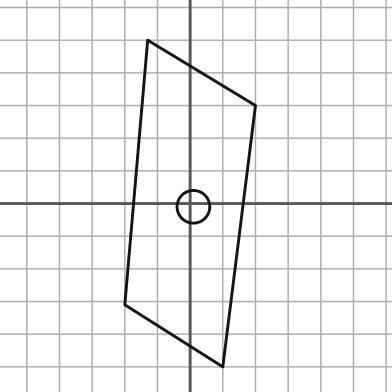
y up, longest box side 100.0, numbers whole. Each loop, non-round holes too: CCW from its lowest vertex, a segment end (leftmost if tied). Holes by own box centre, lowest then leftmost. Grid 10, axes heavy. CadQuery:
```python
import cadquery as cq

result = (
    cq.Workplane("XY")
    .moveTo(10.0, -50.0)
    .lineTo(20.0, 30.0)
    .lineTo(-13.0, 50.0)
    .lineTo(-20.0, -31.0)
    .close()
    .moveTo(1.0, -1.0)
    .circle(5.0)
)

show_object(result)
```